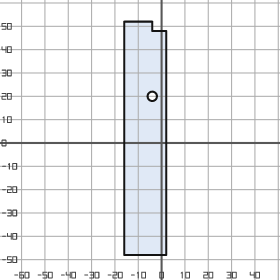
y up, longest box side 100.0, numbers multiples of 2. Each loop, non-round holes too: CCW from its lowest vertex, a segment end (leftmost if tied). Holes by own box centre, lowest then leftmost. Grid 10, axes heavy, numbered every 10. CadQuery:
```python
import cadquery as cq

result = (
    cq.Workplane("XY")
    .moveTo(-16.0, -48.0)
    .lineTo(2.0, -48.0)
    .lineTo(2.0, 48.0)
    .lineTo(-4.0, 48.0)
    .lineTo(-4.0, 52.0)
    .lineTo(-16.0, 52.0)
    .close()
    .moveTo(-4.0, 20.0)
    .circle(2.0)
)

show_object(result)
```